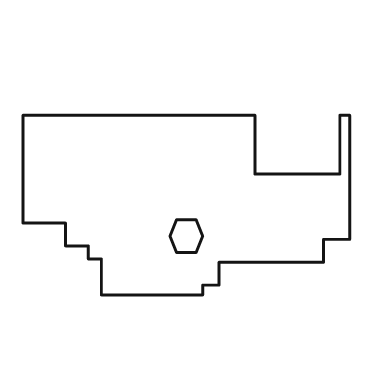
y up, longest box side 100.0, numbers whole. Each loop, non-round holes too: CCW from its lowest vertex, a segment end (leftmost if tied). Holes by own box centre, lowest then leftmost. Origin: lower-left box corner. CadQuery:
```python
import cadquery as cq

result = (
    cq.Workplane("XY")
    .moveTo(24.0, 0.0)
    .lineTo(55.0, 0.0)
    .lineTo(55.0, 3.0)
    .lineTo(60.0, 3.0)
    .lineTo(60.0, 10.0)
    .lineTo(92.0, 10.0)
    .lineTo(92.0, 17.0)
    .lineTo(100.0, 17.0)
    .lineTo(100.0, 55.0)
    .lineTo(97.0, 55.0)
    .lineTo(97.0, 37.0)
    .lineTo(71.0, 37.0)
    .lineTo(71.0, 55.0)
    .lineTo(0.0, 55.0)
    .lineTo(0.0, 22.0)
    .lineTo(13.0, 22.0)
    .lineTo(13.0, 15.0)
    .lineTo(20.0, 15.0)
    .lineTo(20.0, 11.0)
    .lineTo(24.0, 11.0)
    .close()
    .moveTo(47.0, 13.0)
    .lineTo(53.0, 13.0)
    .lineTo(55.0, 18.0)
    .lineTo(53.0, 23.0)
    .lineTo(47.0, 23.0)
    .lineTo(45.0, 18.0)
    .close()
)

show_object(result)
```